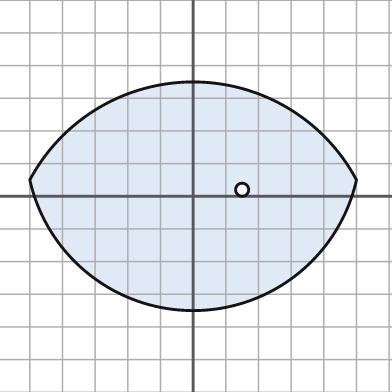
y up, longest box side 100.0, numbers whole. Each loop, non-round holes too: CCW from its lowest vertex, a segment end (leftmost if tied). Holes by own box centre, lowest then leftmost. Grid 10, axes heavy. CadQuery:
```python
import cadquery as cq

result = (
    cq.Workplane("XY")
    .moveTo(-50.0, 5.0)
    .threePointArc((0.0, -35.0), (50.0, 5.0))
    .threePointArc((0.0, 35.0), (-50.0, 5.0))
    .close()
    .moveTo(15.0, 2.0)
    .circle(2.0)
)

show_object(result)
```